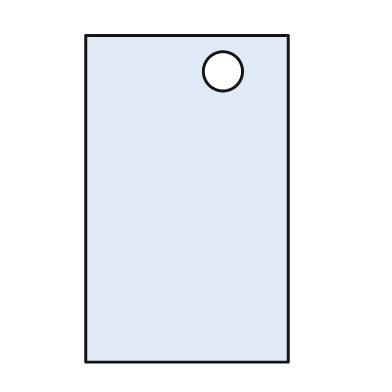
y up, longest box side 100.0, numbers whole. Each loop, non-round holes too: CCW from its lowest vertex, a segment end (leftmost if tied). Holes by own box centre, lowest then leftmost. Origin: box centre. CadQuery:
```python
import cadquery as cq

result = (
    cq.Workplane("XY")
    .moveTo(-31.0, -50.0)
    .lineTo(31.0, -50.0)
    .lineTo(31.0, 50.0)
    .lineTo(-31.0, 50.0)
    .close()
    .moveTo(11.0, 39.0)
    .circle(6.0)
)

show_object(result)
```